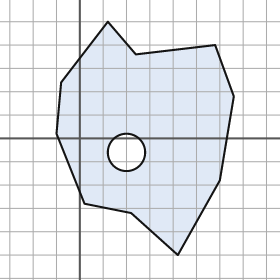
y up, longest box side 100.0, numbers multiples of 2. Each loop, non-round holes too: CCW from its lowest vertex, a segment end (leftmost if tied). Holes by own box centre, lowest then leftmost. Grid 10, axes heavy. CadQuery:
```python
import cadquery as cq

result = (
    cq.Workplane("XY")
    .moveTo(42.0, -50.0)
    .lineTo(60.0, -18.0)
    .lineTo(66.0, 18.0)
    .lineTo(58.0, 40.0)
    .lineTo(24.0, 36.0)
    .lineTo(12.0, 50.0)
    .lineTo(-8.0, 24.0)
    .lineTo(-10.0, 2.0)
    .lineTo(2.0, -28.0)
    .lineTo(22.0, -32.0)
    .close()
    .moveTo(20.0, -6.0)
    .circle(8.0)
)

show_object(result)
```